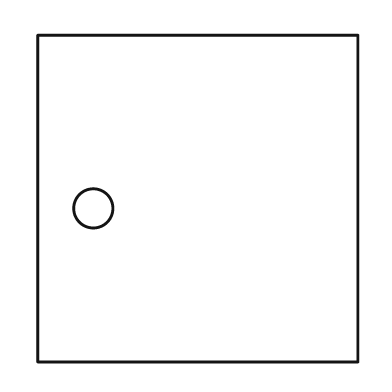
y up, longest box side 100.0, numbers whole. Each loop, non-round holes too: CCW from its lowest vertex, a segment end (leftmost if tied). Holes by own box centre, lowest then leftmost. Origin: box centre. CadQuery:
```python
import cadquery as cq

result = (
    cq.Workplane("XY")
    .moveTo(-49.0, -50.0)
    .lineTo(49.0, -50.0)
    .lineTo(49.0, 50.0)
    .lineTo(-49.0, 50.0)
    .close()
    .moveTo(-32.0, -3.0)
    .circle(6.0)
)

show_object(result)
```